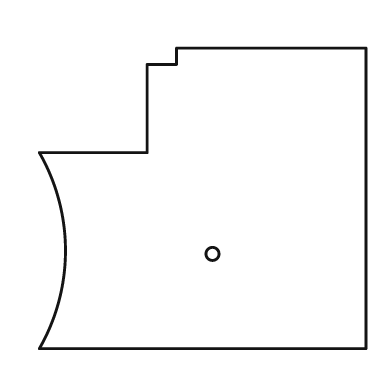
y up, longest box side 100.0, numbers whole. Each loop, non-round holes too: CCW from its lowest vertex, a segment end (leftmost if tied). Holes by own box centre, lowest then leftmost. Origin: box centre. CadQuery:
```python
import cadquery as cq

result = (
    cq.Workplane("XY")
    .moveTo(-50.0, -46.0)
    .lineTo(50.0, -46.0)
    .lineTo(50.0, 46.0)
    .lineTo(-8.0, 46.0)
    .lineTo(-8.0, 41.0)
    .lineTo(-17.0, 41.0)
    .lineTo(-17.0, 14.0)
    .lineTo(-50.0, 14.0)
    .threePointArc((-42.0, -16.0), (-50.0, -46.0))
    .close()
    .moveTo(3.0, -17.0)
    .circle(2.0)
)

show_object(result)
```